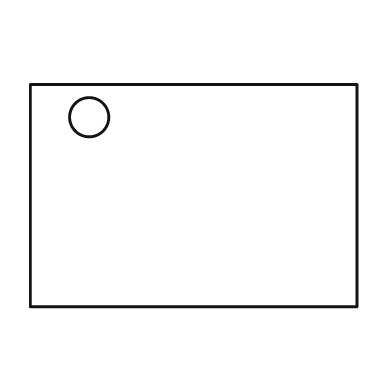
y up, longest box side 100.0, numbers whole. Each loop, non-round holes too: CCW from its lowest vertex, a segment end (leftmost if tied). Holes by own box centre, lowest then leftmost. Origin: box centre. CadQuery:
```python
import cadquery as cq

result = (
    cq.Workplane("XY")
    .moveTo(-50.0, -34.0)
    .lineTo(50.0, -34.0)
    .lineTo(50.0, 34.0)
    .lineTo(-50.0, 34.0)
    .close()
    .moveTo(-32.0, 24.0)
    .circle(6.0)
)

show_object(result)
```